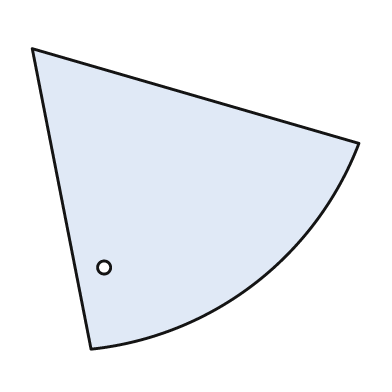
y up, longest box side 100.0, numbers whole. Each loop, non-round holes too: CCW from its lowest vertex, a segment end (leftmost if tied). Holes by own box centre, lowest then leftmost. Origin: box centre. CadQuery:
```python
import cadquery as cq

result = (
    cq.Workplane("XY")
    .moveTo(-32.0, -46.0)
    .threePointArc((18.0, -26.0), (50.0, 17.0))
    .lineTo(-50.0, 46.0)
    .close()
    .moveTo(-28.0, -21.0)
    .circle(2.0)
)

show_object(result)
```